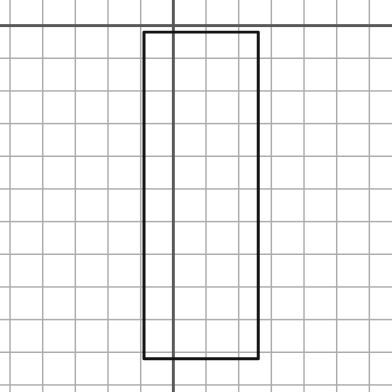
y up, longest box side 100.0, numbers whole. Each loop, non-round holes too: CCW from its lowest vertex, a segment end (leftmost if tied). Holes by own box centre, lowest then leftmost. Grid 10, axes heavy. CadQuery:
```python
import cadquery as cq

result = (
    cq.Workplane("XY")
    .moveTo(-9.0, -102.0)
    .lineTo(26.0, -102.0)
    .lineTo(26.0, -2.0)
    .lineTo(-9.0, -2.0)
    .close()
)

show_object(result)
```